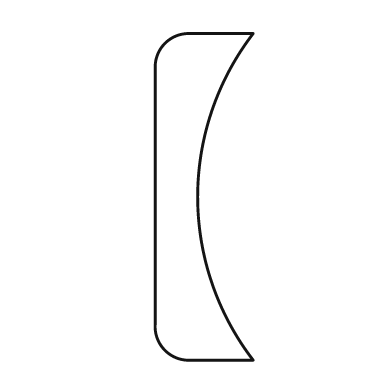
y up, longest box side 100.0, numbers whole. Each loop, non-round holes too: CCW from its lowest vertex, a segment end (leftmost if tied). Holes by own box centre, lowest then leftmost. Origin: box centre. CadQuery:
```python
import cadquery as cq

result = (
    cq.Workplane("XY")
    .moveTo(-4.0, -50.0)
    .lineTo(15.0, -50.0)
    .threePointArc((-2.0, 0.0), (15.0, 50.0))
    .lineTo(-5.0, 50.0)
    .threePointArc((-12.0, 47.0), (-15.0, 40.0))
    .lineTo(-15.0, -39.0)
    .threePointArc((-12.0, -47.0), (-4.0, -50.0))
    .close()
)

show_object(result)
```